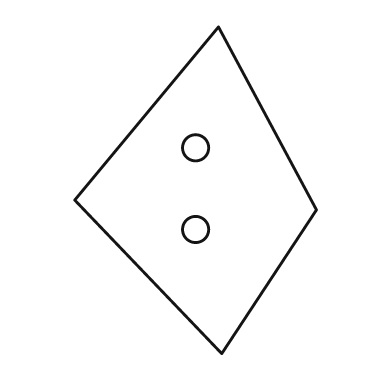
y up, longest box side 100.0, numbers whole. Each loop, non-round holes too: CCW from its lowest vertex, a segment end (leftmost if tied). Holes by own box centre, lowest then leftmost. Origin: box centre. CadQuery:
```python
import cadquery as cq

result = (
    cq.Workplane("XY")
    .moveTo(8.0, -50.0)
    .lineTo(37.0, -6.0)
    .lineTo(7.0, 50.0)
    .lineTo(-37.0, -3.0)
    .close()
    .moveTo(0.0, -12.0)
    .circle(4.0)
    .moveTo(0.0, 13.0)
    .circle(4.0)
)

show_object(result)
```